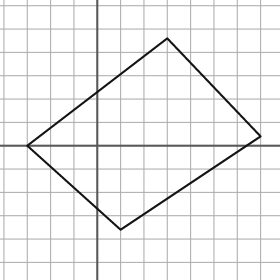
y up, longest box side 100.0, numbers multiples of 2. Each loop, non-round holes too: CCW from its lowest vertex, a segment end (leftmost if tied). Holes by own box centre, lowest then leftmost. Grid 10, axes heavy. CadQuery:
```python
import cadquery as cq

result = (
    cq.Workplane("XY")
    .moveTo(10.0, -36.0)
    .lineTo(70.0, 4.0)
    .lineTo(30.0, 46.0)
    .lineTo(-30.0, 0.0)
    .close()
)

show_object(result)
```